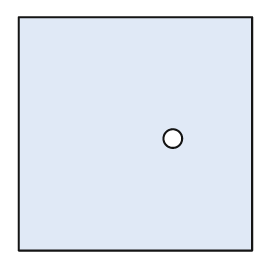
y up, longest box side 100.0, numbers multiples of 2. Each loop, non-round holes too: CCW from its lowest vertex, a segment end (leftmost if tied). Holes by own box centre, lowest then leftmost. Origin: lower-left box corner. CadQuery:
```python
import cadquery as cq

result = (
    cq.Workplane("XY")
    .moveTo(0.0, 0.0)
    .lineTo(100.0, 0.0)
    .lineTo(100.0, 100.0)
    .lineTo(0.0, 100.0)
    .close()
    .moveTo(66.0, 48.0)
    .circle(4.0)
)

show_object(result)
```